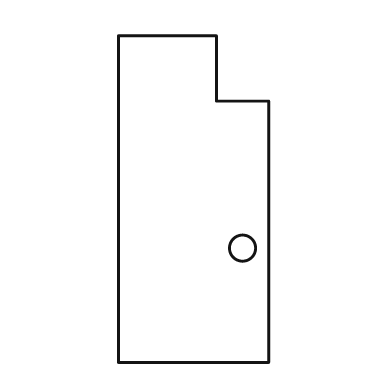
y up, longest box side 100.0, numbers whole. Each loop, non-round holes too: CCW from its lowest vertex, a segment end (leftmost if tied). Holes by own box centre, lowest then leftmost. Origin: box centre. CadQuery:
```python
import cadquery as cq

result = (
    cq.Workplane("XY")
    .moveTo(-23.0, -50.0)
    .lineTo(23.0, -50.0)
    .lineTo(23.0, 30.0)
    .lineTo(7.0, 30.0)
    .lineTo(7.0, 50.0)
    .lineTo(-23.0, 50.0)
    .close()
    .moveTo(15.0, -15.0)
    .circle(4.0)
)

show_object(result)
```